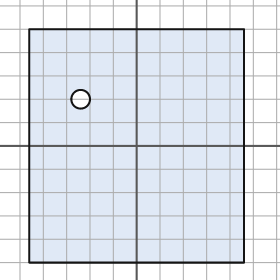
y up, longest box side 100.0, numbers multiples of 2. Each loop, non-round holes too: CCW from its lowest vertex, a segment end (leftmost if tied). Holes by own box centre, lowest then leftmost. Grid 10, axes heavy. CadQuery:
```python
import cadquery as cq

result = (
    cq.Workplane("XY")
    .moveTo(-46.0, -50.0)
    .lineTo(46.0, -50.0)
    .lineTo(46.0, 50.0)
    .lineTo(-46.0, 50.0)
    .close()
    .moveTo(-24.0, 20.0)
    .circle(4.0)
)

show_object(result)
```